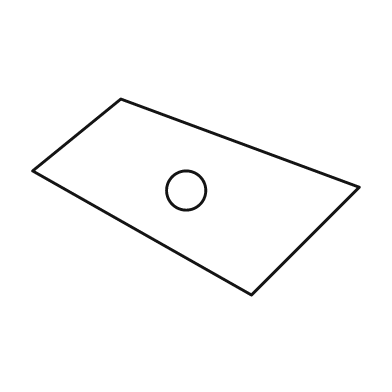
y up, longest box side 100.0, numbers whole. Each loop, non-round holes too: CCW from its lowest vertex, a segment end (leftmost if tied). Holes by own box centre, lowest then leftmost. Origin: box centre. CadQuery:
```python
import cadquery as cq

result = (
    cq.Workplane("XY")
    .moveTo(17.0, -30.0)
    .lineTo(50.0, 3.0)
    .lineTo(-23.0, 30.0)
    .lineTo(-50.0, 8.0)
    .close()
    .moveTo(-3.0, 2.0)
    .circle(6.0)
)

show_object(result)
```